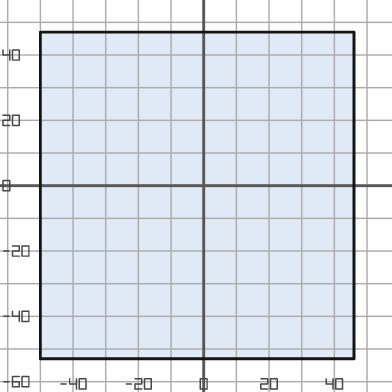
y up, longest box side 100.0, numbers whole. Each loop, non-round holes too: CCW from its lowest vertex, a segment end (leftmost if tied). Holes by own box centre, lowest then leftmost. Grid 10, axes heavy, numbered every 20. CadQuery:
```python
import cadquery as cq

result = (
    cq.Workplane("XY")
    .moveTo(-50.0, -53.0)
    .lineTo(46.0, -53.0)
    .lineTo(46.0, 47.0)
    .lineTo(-50.0, 47.0)
    .close()
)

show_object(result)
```